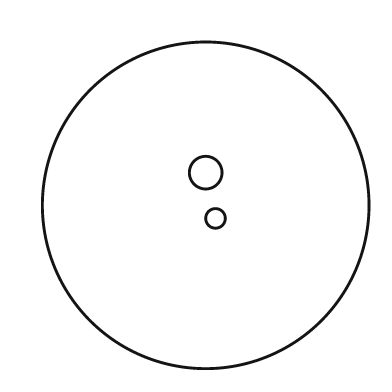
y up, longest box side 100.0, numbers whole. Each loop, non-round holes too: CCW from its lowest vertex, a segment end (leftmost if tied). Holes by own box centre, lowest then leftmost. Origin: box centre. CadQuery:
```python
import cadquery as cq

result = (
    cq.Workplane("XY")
    .moveTo(0.0, 0.0)
    .circle(50.0)
    .moveTo(3.0, -4.0)
    .circle(3.0)
    .moveTo(0.0, 10.0)
    .circle(5.0)
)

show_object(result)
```